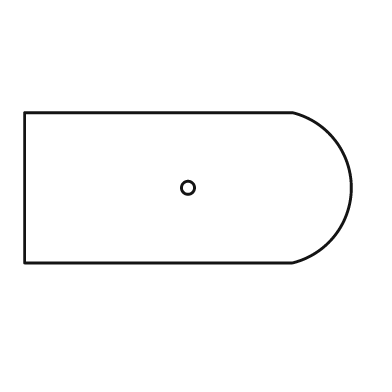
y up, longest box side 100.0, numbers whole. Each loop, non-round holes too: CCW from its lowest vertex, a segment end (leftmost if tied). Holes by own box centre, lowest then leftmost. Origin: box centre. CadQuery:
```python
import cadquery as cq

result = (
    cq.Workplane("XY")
    .moveTo(-50.0, -23.0)
    .lineTo(32.0, -23.0)
    .threePointArc((50.0, 0.0), (32.0, 23.0))
    .lineTo(-50.0, 23.0)
    .close()
    .moveTo(0.0, 0.0)
    .circle(2.0)
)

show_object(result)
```